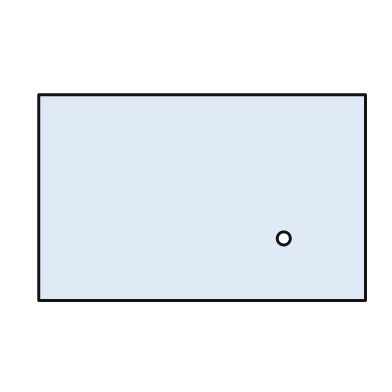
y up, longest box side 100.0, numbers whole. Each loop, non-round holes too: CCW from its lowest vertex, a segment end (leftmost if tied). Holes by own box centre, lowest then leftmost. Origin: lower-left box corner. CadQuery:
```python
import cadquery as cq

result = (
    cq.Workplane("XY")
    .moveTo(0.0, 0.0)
    .lineTo(100.0, 0.0)
    .lineTo(100.0, 63.0)
    .lineTo(0.0, 63.0)
    .close()
    .moveTo(75.0, 19.0)
    .circle(2.0)
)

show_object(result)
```